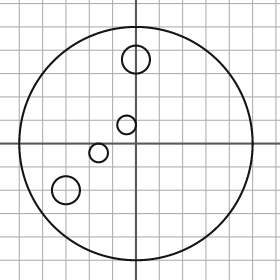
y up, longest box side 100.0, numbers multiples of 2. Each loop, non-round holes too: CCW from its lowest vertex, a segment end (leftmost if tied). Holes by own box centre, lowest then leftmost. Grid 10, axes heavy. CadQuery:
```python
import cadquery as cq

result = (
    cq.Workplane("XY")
    .moveTo(0.0, 0.0)
    .circle(50.0)
    .moveTo(-30.0, -20.0)
    .circle(6.0)
    .moveTo(-16.0, -4.0)
    .circle(4.0)
    .moveTo(-4.0, 8.0)
    .circle(4.0)
    .moveTo(0.0, 36.0)
    .circle(6.0)
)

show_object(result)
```